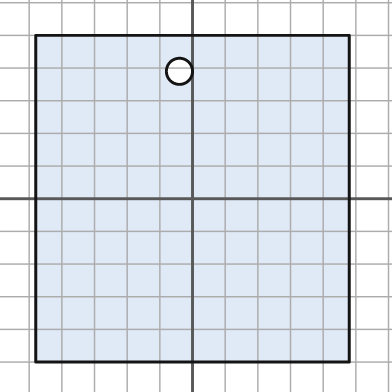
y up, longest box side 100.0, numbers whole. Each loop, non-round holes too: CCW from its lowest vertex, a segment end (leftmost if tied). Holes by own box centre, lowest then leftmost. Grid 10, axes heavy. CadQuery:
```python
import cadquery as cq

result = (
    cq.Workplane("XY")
    .moveTo(-48.0, -50.0)
    .lineTo(48.0, -50.0)
    .lineTo(48.0, 50.0)
    .lineTo(-48.0, 50.0)
    .close()
    .moveTo(-4.0, 39.0)
    .circle(4.0)
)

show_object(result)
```